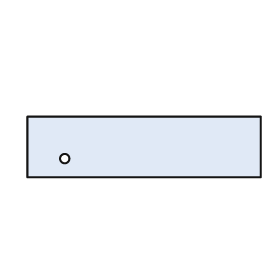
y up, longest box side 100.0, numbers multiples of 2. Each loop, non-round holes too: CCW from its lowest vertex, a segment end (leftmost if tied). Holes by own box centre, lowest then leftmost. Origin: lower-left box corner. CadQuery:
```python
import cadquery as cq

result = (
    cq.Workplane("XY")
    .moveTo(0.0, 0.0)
    .lineTo(100.0, 0.0)
    .lineTo(100.0, 26.0)
    .lineTo(0.0, 26.0)
    .close()
    .moveTo(16.0, 8.0)
    .circle(2.0)
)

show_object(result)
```